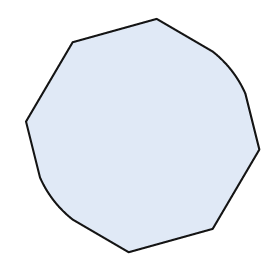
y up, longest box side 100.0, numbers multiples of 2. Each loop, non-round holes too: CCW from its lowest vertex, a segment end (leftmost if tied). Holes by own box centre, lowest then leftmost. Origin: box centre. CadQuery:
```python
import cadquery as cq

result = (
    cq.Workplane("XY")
    .moveTo(-6.0, -50.0)
    .lineTo(30.0, -40.0)
    .lineTo(50.0, -6.0)
    .lineTo(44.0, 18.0)
    .threePointArc((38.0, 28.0), (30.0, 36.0))
    .lineTo(6.0, 50.0)
    .lineTo(-30.0, 40.0)
    .lineTo(-50.0, 6.0)
    .lineTo(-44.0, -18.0)
    .threePointArc((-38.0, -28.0), (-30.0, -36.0))
    .close()
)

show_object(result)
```